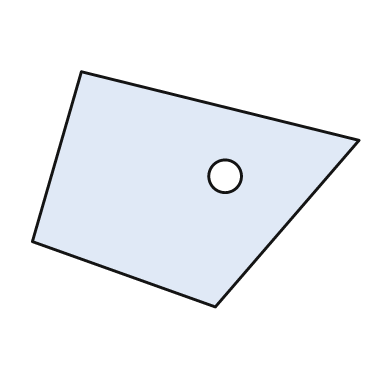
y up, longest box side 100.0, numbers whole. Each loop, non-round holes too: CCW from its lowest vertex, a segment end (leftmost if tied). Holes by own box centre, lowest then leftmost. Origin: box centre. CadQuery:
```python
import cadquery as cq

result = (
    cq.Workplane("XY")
    .moveTo(6.0, -36.0)
    .lineTo(50.0, 15.0)
    .lineTo(-35.0, 36.0)
    .lineTo(-50.0, -16.0)
    .close()
    .moveTo(9.0, 4.0)
    .circle(5.0)
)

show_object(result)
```